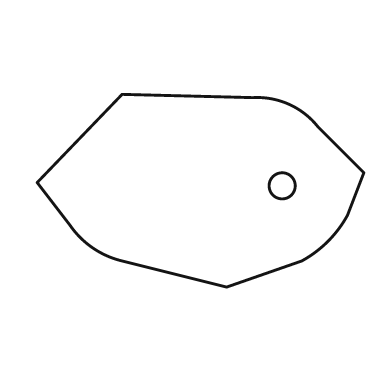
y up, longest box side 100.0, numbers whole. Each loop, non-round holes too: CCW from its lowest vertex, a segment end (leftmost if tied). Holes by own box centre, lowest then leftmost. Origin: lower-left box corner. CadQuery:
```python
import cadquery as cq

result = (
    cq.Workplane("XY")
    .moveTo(58.0, 0.0)
    .lineTo(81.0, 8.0)
    .threePointArc((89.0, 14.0), (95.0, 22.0))
    .lineTo(100.0, 35.0)
    .lineTo(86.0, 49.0)
    .threePointArc((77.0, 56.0), (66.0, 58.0))
    .lineTo(26.0, 59.0)
    .lineTo(0.0, 32.0)
    .lineTo(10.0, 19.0)
    .threePointArc((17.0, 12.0), (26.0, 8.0))
    .close()
    .moveTo(75.0, 31.0)
    .circle(4.0)
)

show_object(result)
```